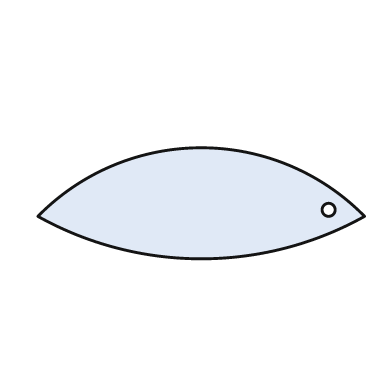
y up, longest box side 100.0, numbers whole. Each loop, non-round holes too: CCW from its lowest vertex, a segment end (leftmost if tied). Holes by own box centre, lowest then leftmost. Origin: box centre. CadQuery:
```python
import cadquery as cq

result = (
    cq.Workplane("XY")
    .moveTo(-50.0, -4.0)
    .threePointArc((0.0, -17.0), (50.0, -4.0))
    .threePointArc((0.0, 17.0), (-50.0, -4.0))
    .close()
    .moveTo(39.0, -2.0)
    .circle(2.0)
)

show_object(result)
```